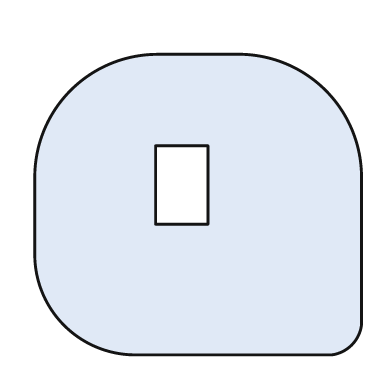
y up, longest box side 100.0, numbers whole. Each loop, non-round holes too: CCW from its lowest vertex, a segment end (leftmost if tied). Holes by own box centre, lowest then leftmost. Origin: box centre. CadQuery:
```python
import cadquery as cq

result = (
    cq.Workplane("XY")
    .moveTo(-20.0, -46.0)
    .lineTo(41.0, -46.0)
    .threePointArc((47.0, -43.0), (50.0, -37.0))
    .lineTo(50.0, 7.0)
    .threePointArc((39.0, 35.0), (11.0, 46.0))
    .lineTo(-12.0, 46.0)
    .threePointArc((-39.0, 35.0), (-50.0, 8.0))
    .lineTo(-50.0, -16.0)
    .threePointArc((-41.0, -37.0), (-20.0, -46.0))
    .close()
    .moveTo(-13.0, -6.0)
    .lineTo(3.0, -6.0)
    .lineTo(3.0, 18.0)
    .lineTo(-13.0, 18.0)
    .close()
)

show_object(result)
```